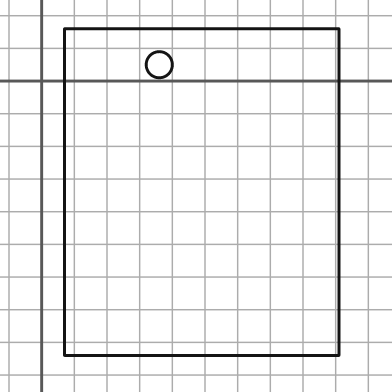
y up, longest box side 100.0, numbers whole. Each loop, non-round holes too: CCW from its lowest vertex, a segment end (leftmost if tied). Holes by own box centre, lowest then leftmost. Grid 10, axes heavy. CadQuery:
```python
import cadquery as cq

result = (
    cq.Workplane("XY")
    .moveTo(7.0, -84.0)
    .lineTo(91.0, -84.0)
    .lineTo(91.0, 16.0)
    .lineTo(7.0, 16.0)
    .close()
    .moveTo(36.0, 5.0)
    .circle(4.0)
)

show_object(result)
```